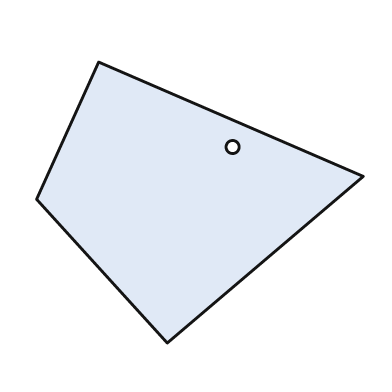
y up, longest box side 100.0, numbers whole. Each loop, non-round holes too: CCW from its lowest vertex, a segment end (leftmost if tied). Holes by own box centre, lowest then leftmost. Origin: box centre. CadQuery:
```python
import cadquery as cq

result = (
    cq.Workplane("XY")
    .moveTo(-10.0, -43.0)
    .lineTo(50.0, 8.0)
    .lineTo(-31.0, 43.0)
    .lineTo(-50.0, 1.0)
    .close()
    .moveTo(10.0, 17.0)
    .circle(2.0)
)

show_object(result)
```